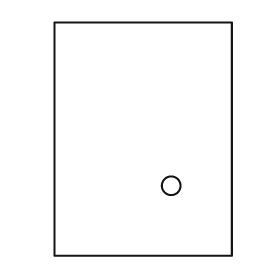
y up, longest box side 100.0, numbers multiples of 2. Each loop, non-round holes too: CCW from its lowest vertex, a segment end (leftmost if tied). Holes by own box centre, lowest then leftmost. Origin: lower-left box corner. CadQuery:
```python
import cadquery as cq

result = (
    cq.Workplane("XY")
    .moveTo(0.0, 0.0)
    .lineTo(76.0, 0.0)
    .lineTo(76.0, 100.0)
    .lineTo(0.0, 100.0)
    .close()
    .moveTo(50.0, 30.0)
    .circle(4.0)
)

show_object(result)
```